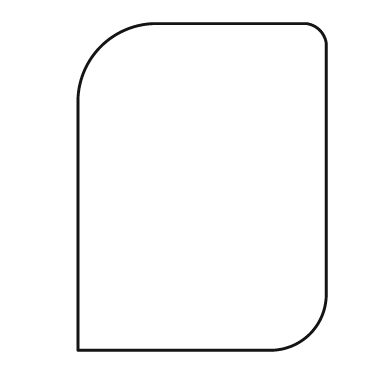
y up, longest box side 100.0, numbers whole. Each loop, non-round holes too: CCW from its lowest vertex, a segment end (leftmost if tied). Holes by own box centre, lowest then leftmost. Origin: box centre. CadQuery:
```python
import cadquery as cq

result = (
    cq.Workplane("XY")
    .moveTo(-38.0, -50.0)
    .lineTo(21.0, -50.0)
    .threePointArc((33.0, -45.0), (38.0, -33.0))
    .lineTo(38.0, 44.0)
    .threePointArc((36.0, 48.0), (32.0, 50.0))
    .lineTo(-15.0, 50.0)
    .threePointArc((-31.0, 43.0), (-38.0, 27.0))
    .close()
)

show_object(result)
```